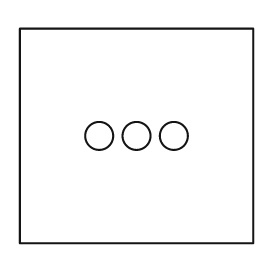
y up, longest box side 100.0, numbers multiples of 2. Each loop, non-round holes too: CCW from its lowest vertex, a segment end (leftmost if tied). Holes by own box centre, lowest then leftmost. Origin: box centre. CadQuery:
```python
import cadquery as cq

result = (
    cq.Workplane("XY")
    .moveTo(-50.0, -46.0)
    .lineTo(50.0, -46.0)
    .lineTo(50.0, 46.0)
    .lineTo(-50.0, 46.0)
    .close()
    .moveTo(-16.0, 0.0)
    .circle(6.0)
    .moveTo(0.0, 0.0)
    .circle(6.0)
    .moveTo(16.0, 0.0)
    .circle(6.0)
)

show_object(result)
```